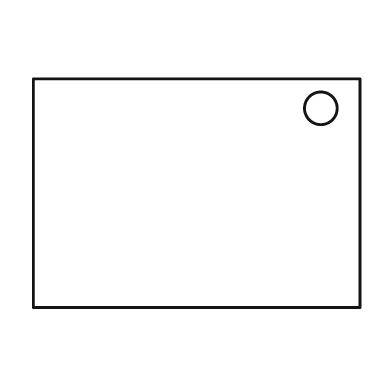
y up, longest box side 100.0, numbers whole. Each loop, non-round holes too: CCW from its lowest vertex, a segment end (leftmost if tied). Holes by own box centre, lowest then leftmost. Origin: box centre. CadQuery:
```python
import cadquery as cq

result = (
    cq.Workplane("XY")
    .moveTo(-50.0, -35.0)
    .lineTo(50.0, -35.0)
    .lineTo(50.0, 35.0)
    .lineTo(-50.0, 35.0)
    .close()
    .moveTo(38.0, 26.0)
    .circle(5.0)
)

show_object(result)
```